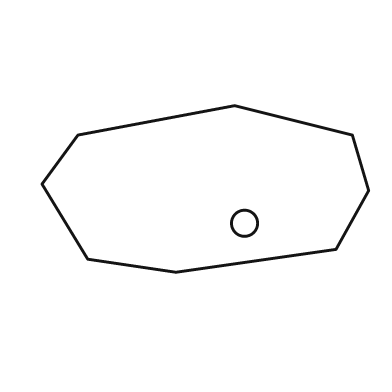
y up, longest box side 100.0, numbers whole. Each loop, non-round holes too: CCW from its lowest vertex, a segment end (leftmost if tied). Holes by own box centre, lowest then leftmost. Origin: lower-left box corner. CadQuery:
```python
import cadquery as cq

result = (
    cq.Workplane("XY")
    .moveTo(41.0, 0.0)
    .lineTo(90.0, 7.0)
    .lineTo(100.0, 25.0)
    .lineTo(95.0, 42.0)
    .lineTo(59.0, 51.0)
    .lineTo(11.0, 42.0)
    .lineTo(0.0, 27.0)
    .lineTo(14.0, 4.0)
    .close()
    .moveTo(62.0, 15.0)
    .circle(4.0)
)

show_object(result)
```